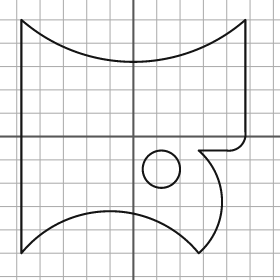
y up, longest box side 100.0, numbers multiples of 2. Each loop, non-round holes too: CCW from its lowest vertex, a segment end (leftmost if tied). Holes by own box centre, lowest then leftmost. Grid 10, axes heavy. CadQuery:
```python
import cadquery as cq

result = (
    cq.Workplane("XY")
    .moveTo(-48.0, -50.0)
    .threePointArc((-10.0, -32.0), (28.0, -50.0))
    .threePointArc((38.0, -28.0), (28.0, -6.0))
    .lineTo(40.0, -6.0)
    .threePointArc((46.0, -4.0), (48.0, 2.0))
    .lineTo(48.0, 50.0)
    .threePointArc((0.0, 32.0), (-48.0, 50.0))
    .close()
    .moveTo(12.0, -14.0)
    .circle(8.0)
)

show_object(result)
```